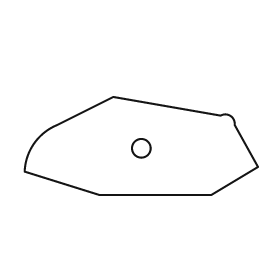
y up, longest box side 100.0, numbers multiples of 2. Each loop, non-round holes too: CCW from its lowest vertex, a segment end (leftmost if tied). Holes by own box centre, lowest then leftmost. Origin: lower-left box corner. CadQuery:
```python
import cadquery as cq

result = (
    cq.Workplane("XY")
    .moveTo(32.0, 0.0)
    .lineTo(80.0, 0.0)
    .lineTo(100.0, 12.0)
    .lineTo(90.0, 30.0)
    .threePointArc((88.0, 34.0), (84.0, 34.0))
    .lineTo(38.0, 42.0)
    .lineTo(14.0, 30.0)
    .threePointArc((4.0, 22.0), (0.0, 10.0))
    .close()
    .moveTo(50.0, 20.0)
    .circle(4.0)
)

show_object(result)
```